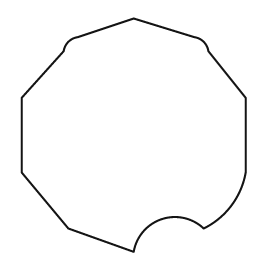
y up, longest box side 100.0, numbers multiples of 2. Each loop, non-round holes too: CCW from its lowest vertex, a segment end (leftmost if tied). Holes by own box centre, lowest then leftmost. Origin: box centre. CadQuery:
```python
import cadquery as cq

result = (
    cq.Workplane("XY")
    .moveTo(0.0, -50.0)
    .threePointArc((12.0, -36.0), (30.0, -40.0))
    .threePointArc((42.0, -30.0), (48.0, -16.0))
    .lineTo(48.0, 16.0)
    .lineTo(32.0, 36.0)
    .threePointArc((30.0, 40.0), (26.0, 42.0))
    .lineTo(0.0, 50.0)
    .lineTo(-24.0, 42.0)
    .threePointArc((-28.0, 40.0), (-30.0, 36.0))
    .lineTo(-48.0, 16.0)
    .lineTo(-48.0, -16.0)
    .lineTo(-28.0, -40.0)
    .close()
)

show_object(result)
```